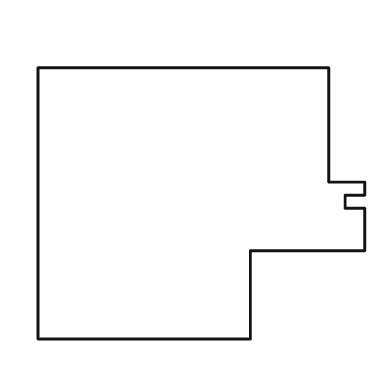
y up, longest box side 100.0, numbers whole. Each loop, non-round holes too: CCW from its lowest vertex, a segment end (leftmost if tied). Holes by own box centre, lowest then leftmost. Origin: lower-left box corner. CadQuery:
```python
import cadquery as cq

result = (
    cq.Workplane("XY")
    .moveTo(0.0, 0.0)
    .lineTo(65.0, 0.0)
    .lineTo(65.0, 27.0)
    .lineTo(100.0, 27.0)
    .lineTo(100.0, 40.0)
    .lineTo(94.0, 40.0)
    .lineTo(94.0, 44.0)
    .lineTo(100.0, 44.0)
    .lineTo(100.0, 48.0)
    .lineTo(89.0, 48.0)
    .lineTo(89.0, 83.0)
    .lineTo(0.0, 83.0)
    .close()
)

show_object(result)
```